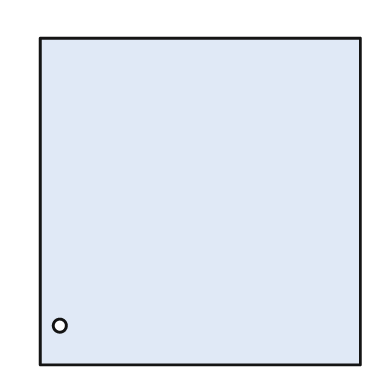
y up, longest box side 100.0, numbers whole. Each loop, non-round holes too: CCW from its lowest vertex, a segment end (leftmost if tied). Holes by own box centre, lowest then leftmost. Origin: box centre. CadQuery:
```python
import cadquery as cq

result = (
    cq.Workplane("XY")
    .moveTo(-49.0, -50.0)
    .lineTo(49.0, -50.0)
    .lineTo(49.0, 50.0)
    .lineTo(-49.0, 50.0)
    .close()
    .moveTo(-43.0, -38.0)
    .circle(2.0)
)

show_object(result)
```